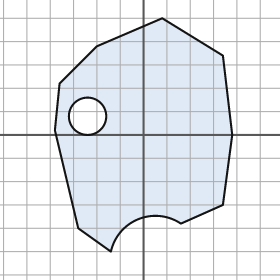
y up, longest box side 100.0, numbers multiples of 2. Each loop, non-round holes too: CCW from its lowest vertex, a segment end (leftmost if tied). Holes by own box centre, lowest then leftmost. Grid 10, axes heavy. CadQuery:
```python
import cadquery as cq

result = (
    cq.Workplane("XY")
    .moveTo(-14.0, -50.0)
    .threePointArc((-2.0, -36.0), (16.0, -38.0))
    .lineTo(34.0, -30.0)
    .lineTo(38.0, 0.0)
    .lineTo(34.0, 34.0)
    .lineTo(8.0, 50.0)
    .lineTo(-20.0, 38.0)
    .lineTo(-36.0, 22.0)
    .lineTo(-38.0, 2.0)
    .lineTo(-28.0, -40.0)
    .close()
    .moveTo(-24.0, 8.0)
    .circle(8.0)
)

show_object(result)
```